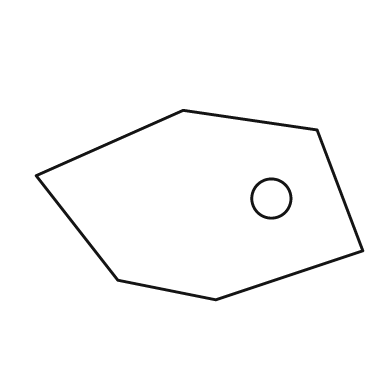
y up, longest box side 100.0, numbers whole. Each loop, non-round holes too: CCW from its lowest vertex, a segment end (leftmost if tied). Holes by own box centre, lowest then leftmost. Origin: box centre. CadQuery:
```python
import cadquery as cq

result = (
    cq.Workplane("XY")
    .moveTo(5.0, -29.0)
    .lineTo(50.0, -14.0)
    .lineTo(36.0, 23.0)
    .lineTo(-5.0, 29.0)
    .lineTo(-50.0, 9.0)
    .lineTo(-25.0, -23.0)
    .close()
    .moveTo(22.0, 2.0)
    .circle(6.0)
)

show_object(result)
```